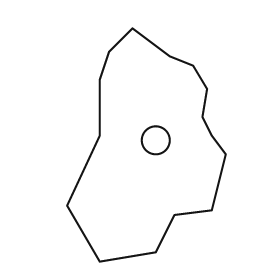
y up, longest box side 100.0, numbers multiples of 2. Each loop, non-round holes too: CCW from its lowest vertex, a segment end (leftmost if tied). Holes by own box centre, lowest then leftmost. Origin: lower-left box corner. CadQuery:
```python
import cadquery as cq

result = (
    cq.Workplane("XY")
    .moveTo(14.0, 0.0)
    .lineTo(38.0, 4.0)
    .lineTo(46.0, 20.0)
    .lineTo(62.0, 22.0)
    .lineTo(68.0, 46.0)
    .lineTo(62.0, 54.0)
    .lineTo(58.0, 62.0)
    .lineTo(60.0, 74.0)
    .lineTo(54.0, 84.0)
    .lineTo(44.0, 88.0)
    .lineTo(28.0, 100.0)
    .lineTo(18.0, 90.0)
    .lineTo(14.0, 78.0)
    .lineTo(14.0, 54.0)
    .lineTo(0.0, 24.0)
    .close()
    .moveTo(38.0, 52.0)
    .circle(6.0)
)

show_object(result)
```